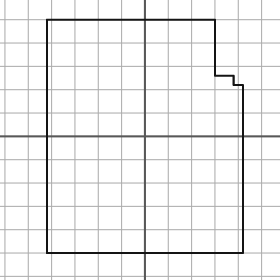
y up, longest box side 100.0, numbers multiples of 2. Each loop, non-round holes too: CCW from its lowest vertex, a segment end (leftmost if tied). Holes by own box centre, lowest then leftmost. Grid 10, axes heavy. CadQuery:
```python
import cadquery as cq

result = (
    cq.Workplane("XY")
    .moveTo(-42.0, -50.0)
    .lineTo(42.0, -50.0)
    .lineTo(42.0, 22.0)
    .lineTo(38.0, 22.0)
    .lineTo(38.0, 26.0)
    .lineTo(30.0, 26.0)
    .lineTo(30.0, 50.0)
    .lineTo(-42.0, 50.0)
    .close()
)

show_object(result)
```